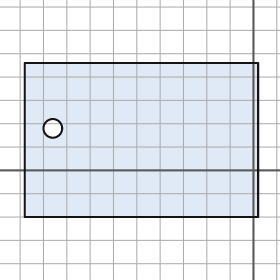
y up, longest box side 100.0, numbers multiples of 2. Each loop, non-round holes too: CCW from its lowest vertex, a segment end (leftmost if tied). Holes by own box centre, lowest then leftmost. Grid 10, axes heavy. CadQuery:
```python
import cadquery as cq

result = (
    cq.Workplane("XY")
    .moveTo(-98.0, -20.0)
    .lineTo(2.0, -20.0)
    .lineTo(2.0, 46.0)
    .lineTo(-98.0, 46.0)
    .close()
    .moveTo(-86.0, 18.0)
    .circle(4.0)
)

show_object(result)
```